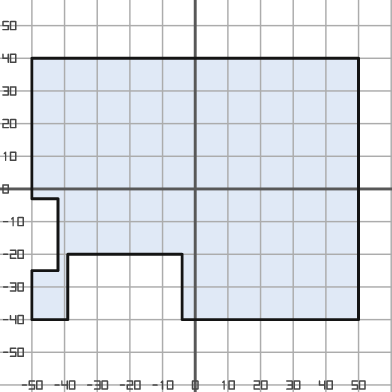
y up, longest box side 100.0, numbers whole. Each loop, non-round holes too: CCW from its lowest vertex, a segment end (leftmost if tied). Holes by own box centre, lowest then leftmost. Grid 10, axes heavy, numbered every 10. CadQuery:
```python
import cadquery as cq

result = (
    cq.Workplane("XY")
    .moveTo(-50.0, -40.0)
    .lineTo(-39.0, -40.0)
    .lineTo(-39.0, -20.0)
    .lineTo(-4.0, -20.0)
    .lineTo(-4.0, -40.0)
    .lineTo(50.0, -40.0)
    .lineTo(50.0, 40.0)
    .lineTo(-50.0, 40.0)
    .lineTo(-50.0, -3.0)
    .lineTo(-42.0, -3.0)
    .lineTo(-42.0, -25.0)
    .lineTo(-50.0, -25.0)
    .close()
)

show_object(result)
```